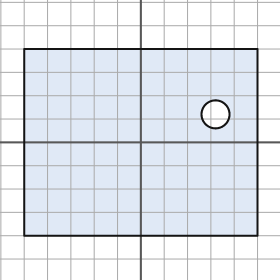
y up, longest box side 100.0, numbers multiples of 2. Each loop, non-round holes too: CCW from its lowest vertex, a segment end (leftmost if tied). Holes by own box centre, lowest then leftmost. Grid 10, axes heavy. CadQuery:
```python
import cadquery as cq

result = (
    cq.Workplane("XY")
    .moveTo(-50.0, -40.0)
    .lineTo(50.0, -40.0)
    .lineTo(50.0, 40.0)
    .lineTo(-50.0, 40.0)
    .close()
    .moveTo(32.0, 12.0)
    .circle(6.0)
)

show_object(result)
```